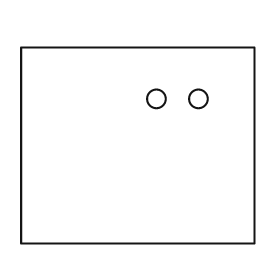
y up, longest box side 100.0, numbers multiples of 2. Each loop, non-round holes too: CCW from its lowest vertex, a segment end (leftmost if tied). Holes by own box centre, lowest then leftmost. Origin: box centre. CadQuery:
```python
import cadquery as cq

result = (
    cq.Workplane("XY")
    .moveTo(-50.0, -42.0)
    .lineTo(50.0, -42.0)
    .lineTo(50.0, 42.0)
    .lineTo(-50.0, 42.0)
    .close()
    .moveTo(8.0, 20.0)
    .circle(4.0)
    .moveTo(26.0, 20.0)
    .circle(4.0)
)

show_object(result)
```